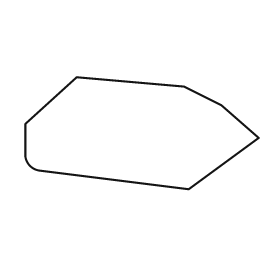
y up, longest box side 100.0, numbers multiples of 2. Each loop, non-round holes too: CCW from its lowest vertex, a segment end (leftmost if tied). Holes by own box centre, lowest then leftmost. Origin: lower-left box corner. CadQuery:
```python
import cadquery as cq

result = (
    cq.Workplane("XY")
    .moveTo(70.0, 0.0)
    .lineTo(100.0, 22.0)
    .lineTo(84.0, 36.0)
    .lineTo(68.0, 44.0)
    .lineTo(22.0, 48.0)
    .lineTo(0.0, 28.0)
    .lineTo(0.0, 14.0)
    .threePointArc((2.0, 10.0), (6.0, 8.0))
    .close()
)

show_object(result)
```